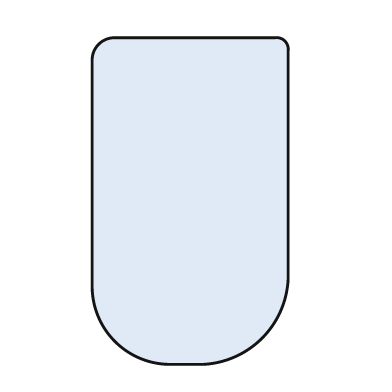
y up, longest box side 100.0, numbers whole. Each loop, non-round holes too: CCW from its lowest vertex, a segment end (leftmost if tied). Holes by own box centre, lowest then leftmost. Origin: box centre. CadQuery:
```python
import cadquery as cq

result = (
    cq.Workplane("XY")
    .moveTo(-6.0, -50.0)
    .lineTo(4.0, -50.0)
    .threePointArc((22.0, -42.0), (30.0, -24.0))
    .lineTo(30.0, 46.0)
    .threePointArc((29.0, 49.0), (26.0, 50.0))
    .lineTo(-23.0, 50.0)
    .threePointArc((-28.0, 48.0), (-30.0, 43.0))
    .lineTo(-30.0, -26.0)
    .threePointArc((-23.0, -43.0), (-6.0, -50.0))
    .close()
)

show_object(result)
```